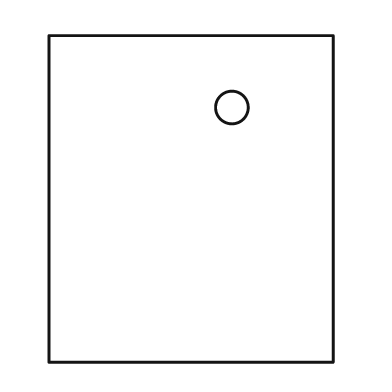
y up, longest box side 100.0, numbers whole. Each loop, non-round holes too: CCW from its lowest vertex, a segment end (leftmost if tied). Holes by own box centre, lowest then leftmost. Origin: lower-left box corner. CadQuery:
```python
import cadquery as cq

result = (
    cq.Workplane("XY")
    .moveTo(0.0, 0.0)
    .lineTo(87.0, 0.0)
    .lineTo(87.0, 100.0)
    .lineTo(0.0, 100.0)
    .close()
    .moveTo(56.0, 78.0)
    .circle(5.0)
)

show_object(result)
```